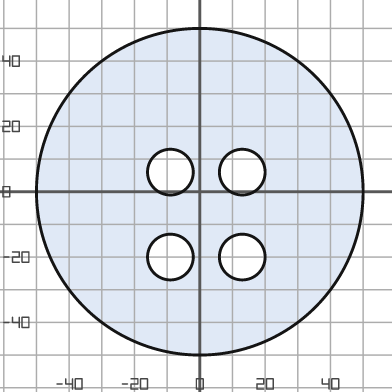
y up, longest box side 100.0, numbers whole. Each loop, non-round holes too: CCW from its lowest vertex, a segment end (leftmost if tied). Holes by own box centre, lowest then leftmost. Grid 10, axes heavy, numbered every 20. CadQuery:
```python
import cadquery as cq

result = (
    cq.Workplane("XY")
    .moveTo(0.0, 0.0)
    .circle(50.0)
    .moveTo(-9.0, -20.0)
    .circle(7.0)
    .moveTo(13.0, -20.0)
    .circle(7.0)
    .moveTo(-9.0, 6.0)
    .circle(7.0)
    .moveTo(13.0, 6.0)
    .circle(7.0)
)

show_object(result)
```